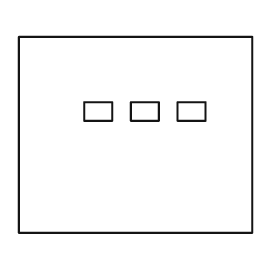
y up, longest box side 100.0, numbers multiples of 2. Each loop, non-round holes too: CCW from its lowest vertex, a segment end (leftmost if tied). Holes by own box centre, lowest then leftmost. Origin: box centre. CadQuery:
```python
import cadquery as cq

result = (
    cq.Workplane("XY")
    .moveTo(-50.0, -42.0)
    .lineTo(50.0, -42.0)
    .lineTo(50.0, 42.0)
    .lineTo(-50.0, 42.0)
    .close()
    .moveTo(-22.0, 6.0)
    .lineTo(-10.0, 6.0)
    .lineTo(-10.0, 14.0)
    .lineTo(-22.0, 14.0)
    .close()
    .moveTo(-2.0, 6.0)
    .lineTo(10.0, 6.0)
    .lineTo(10.0, 14.0)
    .lineTo(-2.0, 14.0)
    .close()
    .moveTo(18.0, 6.0)
    .lineTo(30.0, 6.0)
    .lineTo(30.0, 14.0)
    .lineTo(18.0, 14.0)
    .close()
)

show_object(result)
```